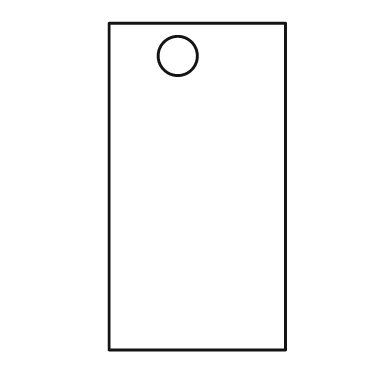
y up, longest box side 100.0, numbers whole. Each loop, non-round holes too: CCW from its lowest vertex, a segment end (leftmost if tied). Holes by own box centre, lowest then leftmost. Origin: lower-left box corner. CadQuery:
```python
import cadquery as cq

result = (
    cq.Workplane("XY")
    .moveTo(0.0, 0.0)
    .lineTo(54.0, 0.0)
    .lineTo(54.0, 100.0)
    .lineTo(0.0, 100.0)
    .close()
    .moveTo(21.0, 90.0)
    .circle(6.0)
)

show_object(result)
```